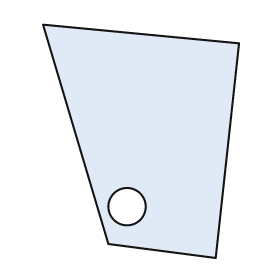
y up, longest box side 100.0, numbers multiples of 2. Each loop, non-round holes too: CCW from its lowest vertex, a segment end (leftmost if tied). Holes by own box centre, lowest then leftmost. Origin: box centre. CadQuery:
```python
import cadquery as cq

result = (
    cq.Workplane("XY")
    .moveTo(32.0, -50.0)
    .lineTo(42.0, 42.0)
    .lineTo(-42.0, 50.0)
    .lineTo(-14.0, -44.0)
    .close()
    .moveTo(-6.0, -28.0)
    .circle(8.0)
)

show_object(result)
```